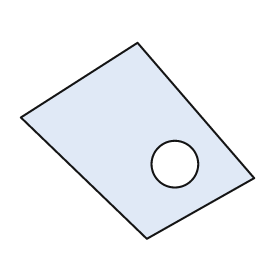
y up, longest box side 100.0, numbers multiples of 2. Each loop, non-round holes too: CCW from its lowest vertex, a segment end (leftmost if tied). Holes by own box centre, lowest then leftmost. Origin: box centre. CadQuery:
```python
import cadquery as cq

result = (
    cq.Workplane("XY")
    .moveTo(4.0, -42.0)
    .lineTo(50.0, -16.0)
    .lineTo(0.0, 42.0)
    .lineTo(-50.0, 10.0)
    .close()
    .moveTo(16.0, -10.0)
    .circle(10.0)
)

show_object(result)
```